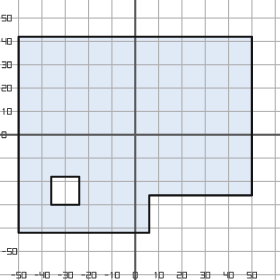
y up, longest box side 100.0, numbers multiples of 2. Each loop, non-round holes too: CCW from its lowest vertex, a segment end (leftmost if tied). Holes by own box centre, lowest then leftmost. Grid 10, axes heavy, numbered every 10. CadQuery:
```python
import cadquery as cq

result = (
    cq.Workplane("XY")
    .moveTo(-50.0, -42.0)
    .lineTo(6.0, -42.0)
    .lineTo(6.0, -26.0)
    .lineTo(50.0, -26.0)
    .lineTo(50.0, 42.0)
    .lineTo(-50.0, 42.0)
    .close()
    .moveTo(-36.0, -30.0)
    .lineTo(-24.0, -30.0)
    .lineTo(-24.0, -18.0)
    .lineTo(-36.0, -18.0)
    .close()
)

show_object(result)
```